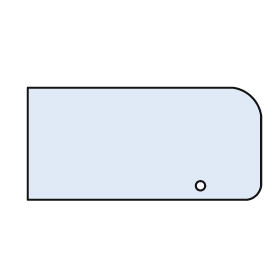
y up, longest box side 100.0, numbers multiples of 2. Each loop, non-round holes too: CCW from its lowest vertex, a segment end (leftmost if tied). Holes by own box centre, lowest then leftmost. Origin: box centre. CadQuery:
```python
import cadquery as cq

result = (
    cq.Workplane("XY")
    .moveTo(-50.0, -24.0)
    .lineTo(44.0, -24.0)
    .threePointArc((48.0, -22.0), (50.0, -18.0))
    .lineTo(50.0, 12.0)
    .threePointArc((46.0, 20.0), (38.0, 24.0))
    .lineTo(-50.0, 24.0)
    .close()
    .moveTo(24.0, -18.0)
    .circle(2.0)
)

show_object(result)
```